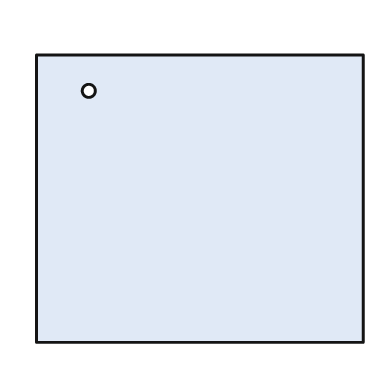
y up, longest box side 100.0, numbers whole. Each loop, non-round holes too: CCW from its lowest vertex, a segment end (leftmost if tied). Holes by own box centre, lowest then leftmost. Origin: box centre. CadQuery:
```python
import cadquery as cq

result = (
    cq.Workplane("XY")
    .moveTo(-50.0, -44.0)
    .lineTo(50.0, -44.0)
    .lineTo(50.0, 44.0)
    .lineTo(-50.0, 44.0)
    .close()
    .moveTo(-34.0, 33.0)
    .circle(2.0)
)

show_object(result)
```